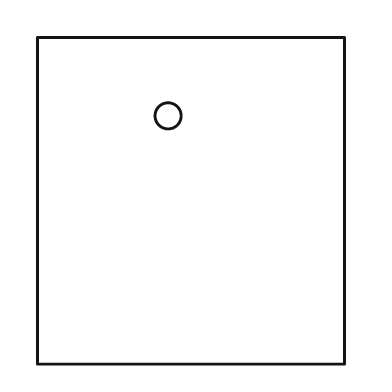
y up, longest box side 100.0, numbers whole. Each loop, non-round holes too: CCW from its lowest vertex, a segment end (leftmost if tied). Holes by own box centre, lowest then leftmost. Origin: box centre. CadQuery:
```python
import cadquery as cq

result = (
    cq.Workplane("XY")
    .moveTo(-47.0, -50.0)
    .lineTo(47.0, -50.0)
    .lineTo(47.0, 50.0)
    .lineTo(-47.0, 50.0)
    .close()
    .moveTo(-7.0, 26.0)
    .circle(4.0)
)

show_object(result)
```